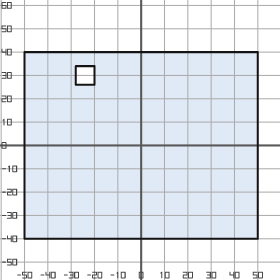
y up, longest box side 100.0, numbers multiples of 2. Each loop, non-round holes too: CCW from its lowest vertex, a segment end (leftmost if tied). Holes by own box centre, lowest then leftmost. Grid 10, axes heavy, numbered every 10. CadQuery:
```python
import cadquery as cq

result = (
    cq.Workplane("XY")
    .moveTo(-50.0, -40.0)
    .lineTo(50.0, -40.0)
    .lineTo(50.0, 40.0)
    .lineTo(-50.0, 40.0)
    .close()
    .moveTo(-28.0, 26.0)
    .lineTo(-20.0, 26.0)
    .lineTo(-20.0, 34.0)
    .lineTo(-28.0, 34.0)
    .close()
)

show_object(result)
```